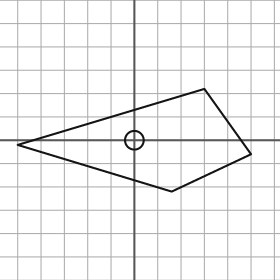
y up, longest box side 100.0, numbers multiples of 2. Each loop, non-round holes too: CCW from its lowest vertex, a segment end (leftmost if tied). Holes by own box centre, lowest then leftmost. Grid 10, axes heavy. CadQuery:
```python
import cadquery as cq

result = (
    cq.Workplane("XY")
    .moveTo(16.0, -22.0)
    .lineTo(50.0, -6.0)
    .lineTo(30.0, 22.0)
    .lineTo(-50.0, -2.0)
    .close()
    .moveTo(0.0, 0.0)
    .circle(4.0)
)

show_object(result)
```